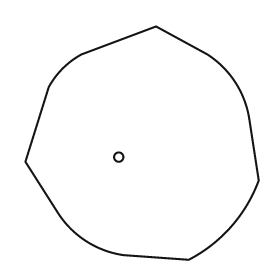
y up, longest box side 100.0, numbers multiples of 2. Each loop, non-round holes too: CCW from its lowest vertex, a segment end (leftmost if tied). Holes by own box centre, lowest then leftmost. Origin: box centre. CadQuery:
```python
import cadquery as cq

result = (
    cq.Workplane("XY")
    .moveTo(20.0, -50.0)
    .threePointArc((38.0, -36.0), (50.0, -16.0))
    .lineTo(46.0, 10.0)
    .threePointArc((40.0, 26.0), (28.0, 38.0))
    .lineTo(6.0, 50.0)
    .lineTo(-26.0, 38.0)
    .threePointArc((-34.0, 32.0), (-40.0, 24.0))
    .lineTo(-50.0, -8.0)
    .lineTo(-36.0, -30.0)
    .threePointArc((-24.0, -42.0), (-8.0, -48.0))
    .close()
    .moveTo(-10.0, -6.0)
    .circle(2.0)
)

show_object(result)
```